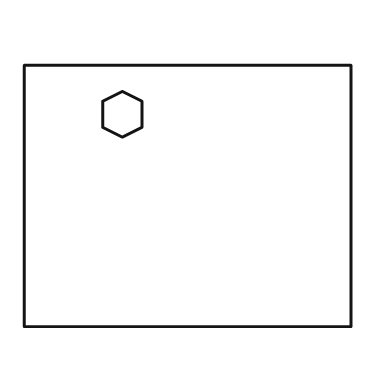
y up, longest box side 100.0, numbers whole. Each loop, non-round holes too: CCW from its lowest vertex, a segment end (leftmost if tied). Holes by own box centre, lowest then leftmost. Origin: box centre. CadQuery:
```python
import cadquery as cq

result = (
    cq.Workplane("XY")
    .moveTo(-50.0, -40.0)
    .lineTo(50.0, -40.0)
    .lineTo(50.0, 40.0)
    .lineTo(-50.0, 40.0)
    .close()
    .moveTo(-20.0, 18.0)
    .lineTo(-14.0, 21.0)
    .lineTo(-14.0, 29.0)
    .lineTo(-20.0, 32.0)
    .lineTo(-26.0, 29.0)
    .lineTo(-26.0, 21.0)
    .close()
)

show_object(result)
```